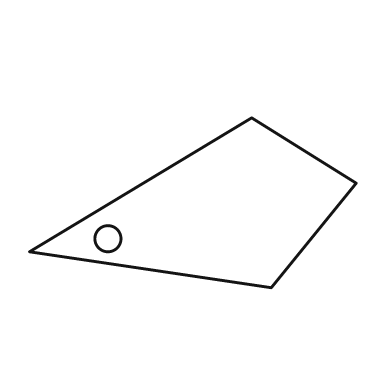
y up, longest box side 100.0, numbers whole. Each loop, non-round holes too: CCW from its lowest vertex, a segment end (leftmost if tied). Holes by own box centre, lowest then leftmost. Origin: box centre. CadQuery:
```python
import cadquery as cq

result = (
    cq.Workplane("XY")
    .moveTo(24.0, -26.0)
    .lineTo(50.0, 6.0)
    .lineTo(18.0, 26.0)
    .lineTo(-50.0, -15.0)
    .close()
    .moveTo(-26.0, -11.0)
    .circle(4.0)
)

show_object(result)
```